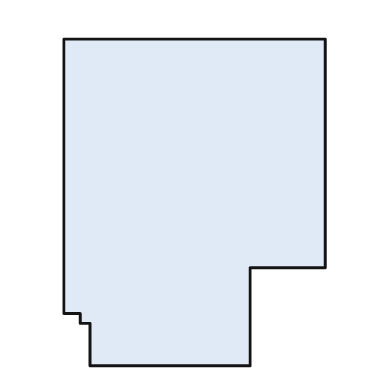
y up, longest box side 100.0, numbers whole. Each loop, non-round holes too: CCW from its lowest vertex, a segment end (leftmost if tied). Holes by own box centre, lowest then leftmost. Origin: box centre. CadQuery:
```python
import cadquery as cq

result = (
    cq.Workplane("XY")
    .moveTo(-32.0, -50.0)
    .lineTo(17.0, -50.0)
    .lineTo(17.0, -20.0)
    .lineTo(40.0, -20.0)
    .lineTo(40.0, 50.0)
    .lineTo(-40.0, 50.0)
    .lineTo(-40.0, -34.0)
    .lineTo(-35.0, -34.0)
    .lineTo(-35.0, -37.0)
    .lineTo(-32.0, -37.0)
    .close()
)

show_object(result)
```